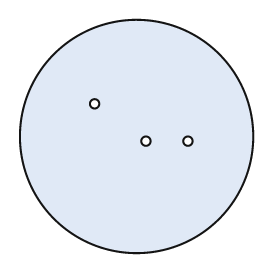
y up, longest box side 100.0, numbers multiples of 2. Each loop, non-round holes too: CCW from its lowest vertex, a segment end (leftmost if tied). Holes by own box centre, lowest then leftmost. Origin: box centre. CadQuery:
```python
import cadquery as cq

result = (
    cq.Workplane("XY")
    .moveTo(0.0, 0.0)
    .circle(50.0)
    .moveTo(4.0, -2.0)
    .circle(2.0)
    .moveTo(22.0, -2.0)
    .circle(2.0)
    .moveTo(-18.0, 14.0)
    .circle(2.0)
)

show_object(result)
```